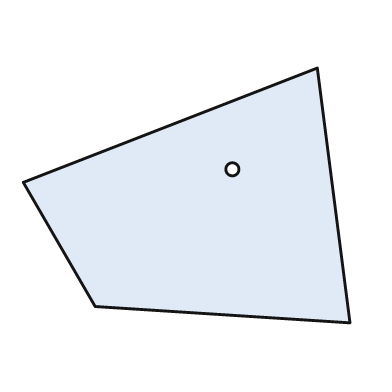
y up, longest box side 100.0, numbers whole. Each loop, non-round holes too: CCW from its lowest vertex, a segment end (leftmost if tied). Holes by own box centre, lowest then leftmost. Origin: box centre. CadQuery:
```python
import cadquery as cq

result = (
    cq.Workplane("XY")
    .moveTo(50.0, -39.0)
    .lineTo(40.0, 39.0)
    .lineTo(-50.0, 4.0)
    .lineTo(-28.0, -34.0)
    .close()
    .moveTo(14.0, 8.0)
    .circle(2.0)
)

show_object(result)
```